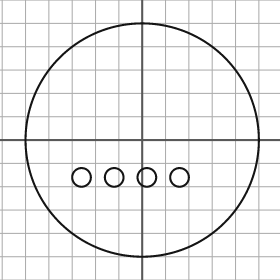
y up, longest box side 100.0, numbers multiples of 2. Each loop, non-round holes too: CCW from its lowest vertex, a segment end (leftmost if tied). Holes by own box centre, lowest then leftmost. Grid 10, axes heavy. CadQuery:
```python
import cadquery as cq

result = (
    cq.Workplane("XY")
    .moveTo(0.0, 0.0)
    .circle(50.0)
    .moveTo(-26.0, -16.0)
    .circle(4.0)
    .moveTo(-12.0, -16.0)
    .circle(4.0)
    .moveTo(2.0, -16.0)
    .circle(4.0)
    .moveTo(16.0, -16.0)
    .circle(4.0)
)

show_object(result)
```